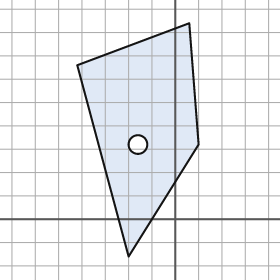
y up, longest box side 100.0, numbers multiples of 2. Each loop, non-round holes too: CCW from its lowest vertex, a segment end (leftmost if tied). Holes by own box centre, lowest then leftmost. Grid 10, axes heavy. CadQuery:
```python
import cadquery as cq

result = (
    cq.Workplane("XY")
    .moveTo(-20.0, -16.0)
    .lineTo(10.0, 32.0)
    .lineTo(6.0, 84.0)
    .lineTo(-42.0, 66.0)
    .close()
    .moveTo(-16.0, 32.0)
    .circle(4.0)
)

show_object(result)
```